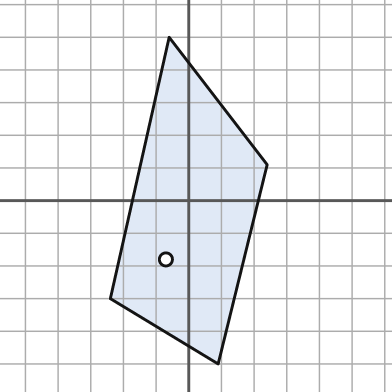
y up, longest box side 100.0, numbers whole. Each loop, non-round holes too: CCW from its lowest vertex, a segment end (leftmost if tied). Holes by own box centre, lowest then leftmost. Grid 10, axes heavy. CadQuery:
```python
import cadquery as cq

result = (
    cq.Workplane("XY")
    .moveTo(9.0, -50.0)
    .lineTo(24.0, 11.0)
    .lineTo(-6.0, 50.0)
    .lineTo(-24.0, -30.0)
    .close()
    .moveTo(-7.0, -18.0)
    .circle(2.0)
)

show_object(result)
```